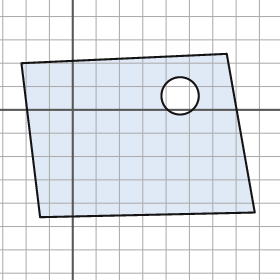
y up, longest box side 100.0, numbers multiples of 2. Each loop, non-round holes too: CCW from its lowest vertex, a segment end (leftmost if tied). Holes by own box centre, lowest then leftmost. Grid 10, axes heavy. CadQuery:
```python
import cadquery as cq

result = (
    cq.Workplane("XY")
    .moveTo(-14.0, -46.0)
    .lineTo(78.0, -44.0)
    .lineTo(66.0, 24.0)
    .lineTo(-22.0, 20.0)
    .close()
    .moveTo(46.0, 6.0)
    .circle(8.0)
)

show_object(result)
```